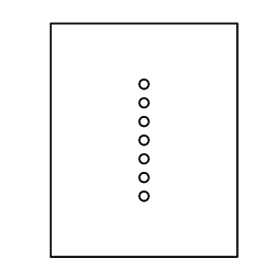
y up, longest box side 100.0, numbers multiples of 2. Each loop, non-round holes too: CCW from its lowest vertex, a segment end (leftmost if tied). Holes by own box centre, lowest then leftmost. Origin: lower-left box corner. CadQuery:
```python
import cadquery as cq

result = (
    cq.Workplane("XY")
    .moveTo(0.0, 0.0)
    .lineTo(80.0, 0.0)
    .lineTo(80.0, 100.0)
    .lineTo(0.0, 100.0)
    .close()
    .moveTo(40.0, 26.0)
    .circle(2.0)
    .moveTo(40.0, 34.0)
    .circle(2.0)
    .moveTo(40.0, 42.0)
    .circle(2.0)
    .moveTo(40.0, 50.0)
    .circle(2.0)
    .moveTo(40.0, 58.0)
    .circle(2.0)
    .moveTo(40.0, 66.0)
    .circle(2.0)
    .moveTo(40.0, 74.0)
    .circle(2.0)
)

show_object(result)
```